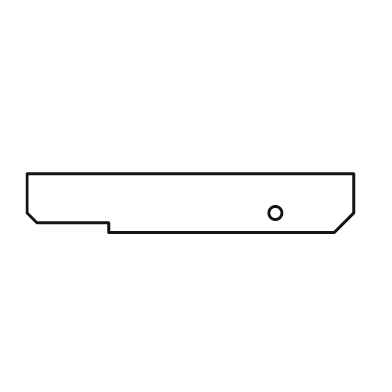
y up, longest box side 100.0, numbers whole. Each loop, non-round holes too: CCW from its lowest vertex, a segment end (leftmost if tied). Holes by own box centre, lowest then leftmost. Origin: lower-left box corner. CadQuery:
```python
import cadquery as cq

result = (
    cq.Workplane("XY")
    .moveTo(25.0, 0.0)
    .lineTo(94.0, 0.0)
    .lineTo(100.0, 6.0)
    .lineTo(100.0, 18.0)
    .lineTo(0.0, 18.0)
    .lineTo(0.0, 6.0)
    .lineTo(3.0, 3.0)
    .lineTo(25.0, 3.0)
    .close()
    .moveTo(76.0, 6.0)
    .circle(2.0)
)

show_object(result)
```